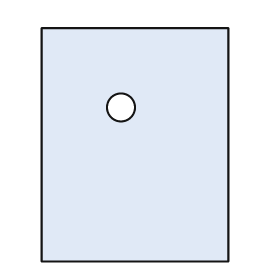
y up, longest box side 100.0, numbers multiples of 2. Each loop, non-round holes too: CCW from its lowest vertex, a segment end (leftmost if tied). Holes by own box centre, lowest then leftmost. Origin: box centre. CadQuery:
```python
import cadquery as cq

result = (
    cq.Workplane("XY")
    .moveTo(-40.0, -50.0)
    .lineTo(40.0, -50.0)
    .lineTo(40.0, 50.0)
    .lineTo(-40.0, 50.0)
    .close()
    .moveTo(-6.0, 16.0)
    .circle(6.0)
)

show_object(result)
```